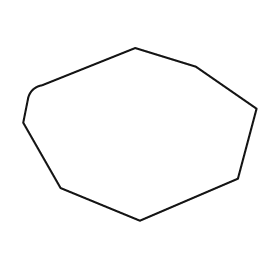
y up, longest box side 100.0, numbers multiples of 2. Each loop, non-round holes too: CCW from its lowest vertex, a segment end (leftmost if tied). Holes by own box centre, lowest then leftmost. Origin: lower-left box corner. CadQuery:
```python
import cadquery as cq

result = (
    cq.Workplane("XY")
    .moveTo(50.0, 0.0)
    .lineTo(92.0, 18.0)
    .lineTo(100.0, 48.0)
    .lineTo(74.0, 66.0)
    .lineTo(48.0, 74.0)
    .lineTo(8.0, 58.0)
    .threePointArc((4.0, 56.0), (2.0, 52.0))
    .lineTo(0.0, 42.0)
    .lineTo(16.0, 14.0)
    .close()
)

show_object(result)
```